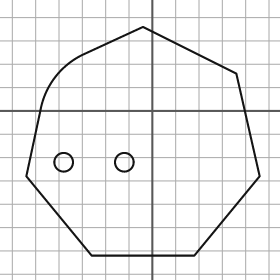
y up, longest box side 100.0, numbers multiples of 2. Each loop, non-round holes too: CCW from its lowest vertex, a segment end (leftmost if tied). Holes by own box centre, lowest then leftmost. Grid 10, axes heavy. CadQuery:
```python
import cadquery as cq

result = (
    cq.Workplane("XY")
    .moveTo(-26.0, -62.0)
    .lineTo(18.0, -62.0)
    .lineTo(46.0, -28.0)
    .lineTo(36.0, 16.0)
    .lineTo(-4.0, 36.0)
    .lineTo(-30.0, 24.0)
    .threePointArc((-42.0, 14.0), (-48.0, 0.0))
    .lineTo(-54.0, -28.0)
    .close()
    .moveTo(-38.0, -22.0)
    .circle(4.0)
    .moveTo(-12.0, -22.0)
    .circle(4.0)
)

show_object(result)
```